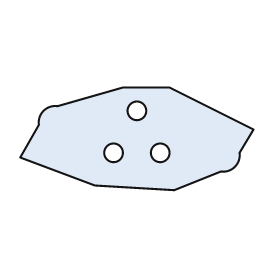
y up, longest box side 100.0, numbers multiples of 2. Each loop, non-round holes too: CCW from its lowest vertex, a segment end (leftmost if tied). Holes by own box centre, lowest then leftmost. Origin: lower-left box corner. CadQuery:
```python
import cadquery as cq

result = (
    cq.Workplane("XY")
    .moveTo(66.0, 0.0)
    .lineTo(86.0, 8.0)
    .threePointArc((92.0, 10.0), (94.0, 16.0))
    .lineTo(100.0, 26.0)
    .lineTo(64.0, 44.0)
    .lineTo(44.0, 44.0)
    .lineTo(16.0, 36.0)
    .threePointArc((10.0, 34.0), (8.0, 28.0))
    .lineTo(0.0, 14.0)
    .lineTo(32.0, 2.0)
    .close()
    .moveTo(40.0, 16.0)
    .circle(4.0)
    .moveTo(60.0, 16.0)
    .circle(4.0)
    .moveTo(50.0, 34.0)
    .circle(4.0)
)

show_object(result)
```